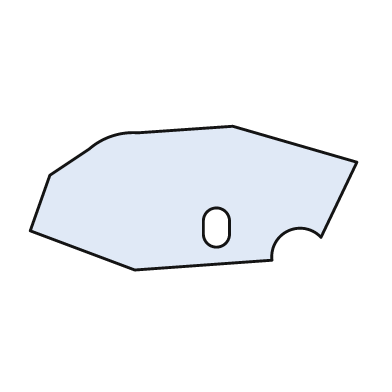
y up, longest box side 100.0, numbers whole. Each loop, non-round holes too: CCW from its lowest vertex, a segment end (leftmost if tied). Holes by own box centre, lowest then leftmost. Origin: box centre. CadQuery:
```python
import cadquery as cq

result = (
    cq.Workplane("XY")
    .moveTo(-18.0, -22.0)
    .lineTo(24.0, -19.0)
    .threePointArc((29.0, -10.0), (39.0, -12.0))
    .lineTo(50.0, 11.0)
    .lineTo(12.0, 22.0)
    .lineTo(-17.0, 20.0)
    .threePointArc((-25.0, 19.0), (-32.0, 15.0))
    .lineTo(-44.0, 7.0)
    .lineTo(-50.0, -10.0)
    .close()
    .moveTo(3.0, -11.0)
    .threePointArc((7.0, -15.0), (11.0, -11.0))
    .lineTo(11.0, -7.0)
    .threePointArc((7.0, -3.0), (3.0, -7.0))
    .close()
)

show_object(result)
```